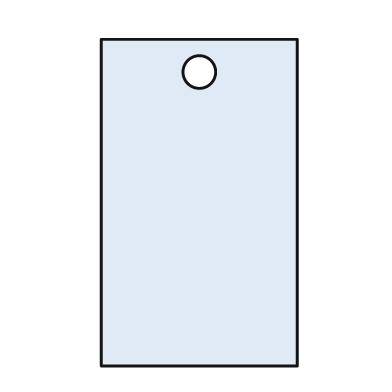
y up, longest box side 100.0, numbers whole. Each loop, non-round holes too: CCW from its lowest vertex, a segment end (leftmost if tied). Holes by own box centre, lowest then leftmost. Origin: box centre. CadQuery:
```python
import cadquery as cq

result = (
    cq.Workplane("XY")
    .moveTo(-30.0, -50.0)
    .lineTo(30.0, -50.0)
    .lineTo(30.0, 50.0)
    .lineTo(-30.0, 50.0)
    .close()
    .moveTo(0.0, 40.0)
    .circle(5.0)
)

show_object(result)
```